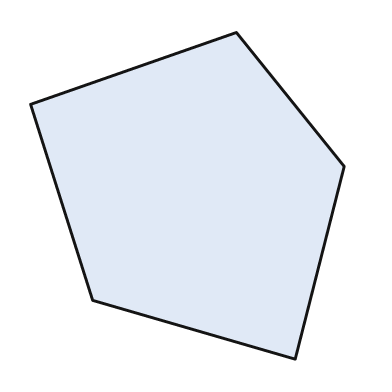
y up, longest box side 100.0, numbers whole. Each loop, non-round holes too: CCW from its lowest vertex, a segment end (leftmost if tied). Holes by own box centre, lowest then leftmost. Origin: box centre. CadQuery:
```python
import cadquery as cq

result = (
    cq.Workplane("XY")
    .moveTo(33.0, -50.0)
    .lineTo(48.0, 9.0)
    .lineTo(15.0, 50.0)
    .lineTo(-48.0, 28.0)
    .lineTo(-29.0, -32.0)
    .close()
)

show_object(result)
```